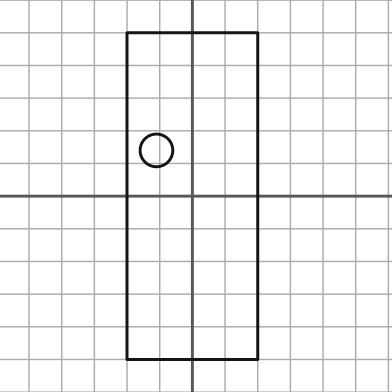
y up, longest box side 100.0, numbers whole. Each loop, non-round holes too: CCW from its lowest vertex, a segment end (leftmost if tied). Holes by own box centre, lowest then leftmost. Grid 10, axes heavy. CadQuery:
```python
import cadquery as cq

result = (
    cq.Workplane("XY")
    .moveTo(-20.0, -50.0)
    .lineTo(20.0, -50.0)
    .lineTo(20.0, 50.0)
    .lineTo(-20.0, 50.0)
    .close()
    .moveTo(-11.0, 14.0)
    .circle(5.0)
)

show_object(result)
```